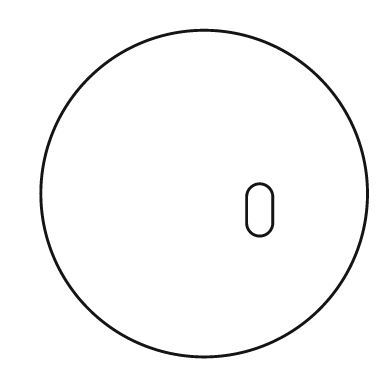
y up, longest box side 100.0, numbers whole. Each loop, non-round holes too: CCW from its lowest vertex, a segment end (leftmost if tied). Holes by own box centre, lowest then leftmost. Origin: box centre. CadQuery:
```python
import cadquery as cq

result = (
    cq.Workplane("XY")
    .moveTo(0.0, 0.0)
    .circle(50.0)
    .moveTo(13.0, -9.0)
    .threePointArc((17.0, -13.0), (21.0, -9.0))
    .lineTo(21.0, -1.0)
    .threePointArc((17.0, 3.0), (13.0, -1.0))
    .close()
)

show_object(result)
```